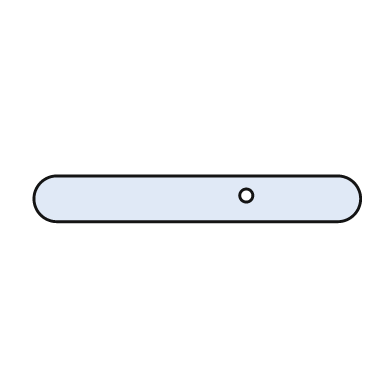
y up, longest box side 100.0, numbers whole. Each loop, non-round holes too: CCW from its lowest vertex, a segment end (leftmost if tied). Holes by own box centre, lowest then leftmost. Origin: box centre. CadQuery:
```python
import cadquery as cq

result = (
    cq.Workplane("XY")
    .moveTo(-43.0, -7.0)
    .lineTo(43.0, -7.0)
    .threePointArc((50.0, 0.0), (43.0, 7.0))
    .lineTo(-43.0, 7.0)
    .threePointArc((-50.0, 0.0), (-43.0, -7.0))
    .close()
    .moveTo(15.0, 1.0)
    .circle(2.0)
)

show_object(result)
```